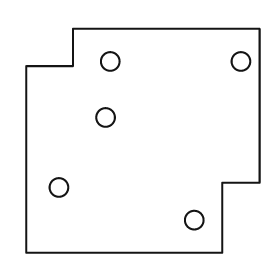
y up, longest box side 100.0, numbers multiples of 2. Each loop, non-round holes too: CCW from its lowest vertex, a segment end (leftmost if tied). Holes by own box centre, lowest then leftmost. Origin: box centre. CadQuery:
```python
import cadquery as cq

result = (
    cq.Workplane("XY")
    .moveTo(-50.0, -48.0)
    .lineTo(34.0, -48.0)
    .lineTo(34.0, -18.0)
    .lineTo(50.0, -18.0)
    .lineTo(50.0, 48.0)
    .lineTo(-30.0, 48.0)
    .lineTo(-30.0, 32.0)
    .lineTo(-50.0, 32.0)
    .close()
    .moveTo(22.0, -34.0)
    .circle(4.0)
    .moveTo(-36.0, -20.0)
    .circle(4.0)
    .moveTo(-16.0, 10.0)
    .circle(4.0)
    .moveTo(-14.0, 34.0)
    .circle(4.0)
    .moveTo(42.0, 34.0)
    .circle(4.0)
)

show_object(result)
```